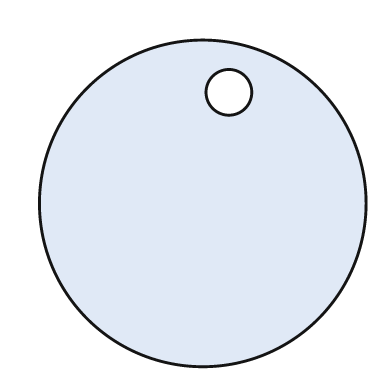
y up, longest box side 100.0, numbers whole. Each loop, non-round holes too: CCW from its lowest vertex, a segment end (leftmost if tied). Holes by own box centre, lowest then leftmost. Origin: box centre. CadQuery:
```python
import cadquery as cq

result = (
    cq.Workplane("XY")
    .moveTo(0.0, 0.0)
    .circle(50.0)
    .moveTo(8.0, 34.0)
    .circle(7.0)
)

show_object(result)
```